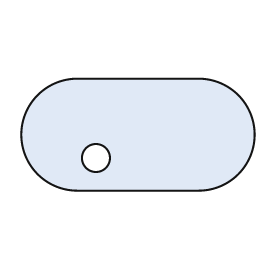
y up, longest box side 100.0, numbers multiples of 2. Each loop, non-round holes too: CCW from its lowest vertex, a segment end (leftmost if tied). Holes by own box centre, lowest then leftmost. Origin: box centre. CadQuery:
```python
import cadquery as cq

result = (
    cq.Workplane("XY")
    .moveTo(-26.0, -24.0)
    .lineTo(26.0, -24.0)
    .threePointArc((50.0, 0.0), (26.0, 24.0))
    .lineTo(-26.0, 24.0)
    .threePointArc((-50.0, 0.0), (-26.0, -24.0))
    .close()
    .moveTo(-18.0, -10.0)
    .circle(6.0)
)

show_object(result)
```